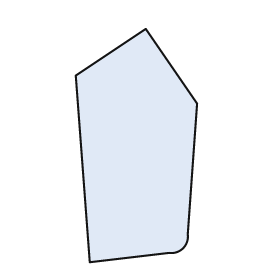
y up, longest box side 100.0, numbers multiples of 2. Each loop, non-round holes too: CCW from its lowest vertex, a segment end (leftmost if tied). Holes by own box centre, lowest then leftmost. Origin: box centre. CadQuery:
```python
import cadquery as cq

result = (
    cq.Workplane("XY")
    .moveTo(-20.0, -50.0)
    .lineTo(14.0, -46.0)
    .threePointArc((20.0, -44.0), (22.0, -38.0))
    .lineTo(26.0, 18.0)
    .lineTo(4.0, 50.0)
    .lineTo(-26.0, 30.0)
    .close()
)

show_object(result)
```